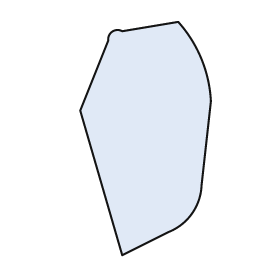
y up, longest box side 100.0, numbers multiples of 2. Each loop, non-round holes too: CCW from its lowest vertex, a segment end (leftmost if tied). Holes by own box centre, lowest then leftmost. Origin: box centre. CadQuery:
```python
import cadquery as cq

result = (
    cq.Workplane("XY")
    .moveTo(-10.0, -50.0)
    .lineTo(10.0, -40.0)
    .threePointArc((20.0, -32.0), (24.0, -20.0))
    .lineTo(28.0, 16.0)
    .threePointArc((24.0, 34.0), (14.0, 50.0))
    .lineTo(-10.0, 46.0)
    .threePointArc((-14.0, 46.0), (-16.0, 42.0))
    .lineTo(-28.0, 12.0)
    .close()
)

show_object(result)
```